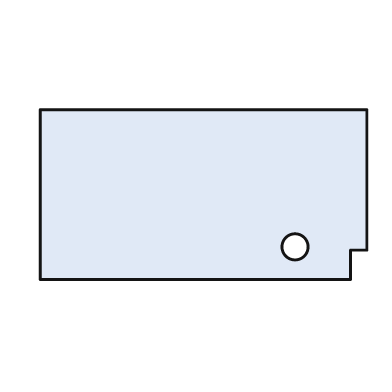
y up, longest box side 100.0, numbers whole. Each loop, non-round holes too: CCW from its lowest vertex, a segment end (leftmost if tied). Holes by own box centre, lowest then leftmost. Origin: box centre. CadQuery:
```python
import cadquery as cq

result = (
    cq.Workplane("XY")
    .moveTo(-50.0, -26.0)
    .lineTo(45.0, -26.0)
    .lineTo(45.0, -17.0)
    .lineTo(50.0, -17.0)
    .lineTo(50.0, 26.0)
    .lineTo(-50.0, 26.0)
    .close()
    .moveTo(28.0, -16.0)
    .circle(4.0)
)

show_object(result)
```